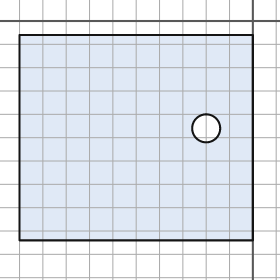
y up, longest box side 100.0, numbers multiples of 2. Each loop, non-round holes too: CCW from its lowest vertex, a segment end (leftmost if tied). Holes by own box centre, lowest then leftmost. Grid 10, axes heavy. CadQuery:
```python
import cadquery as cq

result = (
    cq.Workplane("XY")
    .moveTo(-100.0, -94.0)
    .lineTo(0.0, -94.0)
    .lineTo(0.0, -6.0)
    .lineTo(-100.0, -6.0)
    .close()
    .moveTo(-20.0, -46.0)
    .circle(6.0)
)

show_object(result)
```